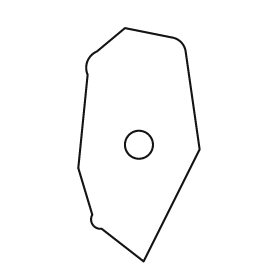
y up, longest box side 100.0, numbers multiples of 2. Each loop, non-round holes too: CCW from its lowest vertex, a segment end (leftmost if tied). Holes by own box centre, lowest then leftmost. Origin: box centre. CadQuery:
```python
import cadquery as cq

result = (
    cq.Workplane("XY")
    .moveTo(2.0, -50.0)
    .lineTo(26.0, -2.0)
    .lineTo(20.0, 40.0)
    .threePointArc((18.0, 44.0), (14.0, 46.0))
    .lineTo(-6.0, 50.0)
    .lineTo(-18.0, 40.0)
    .threePointArc((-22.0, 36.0), (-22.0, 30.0))
    .lineTo(-26.0, -10.0)
    .lineTo(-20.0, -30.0)
    .threePointArc((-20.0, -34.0), (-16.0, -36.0))
    .close()
    .moveTo(0.0, 0.0)
    .circle(6.0)
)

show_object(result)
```